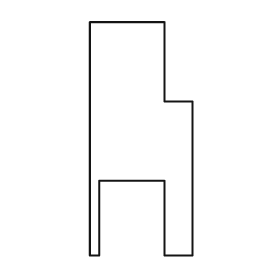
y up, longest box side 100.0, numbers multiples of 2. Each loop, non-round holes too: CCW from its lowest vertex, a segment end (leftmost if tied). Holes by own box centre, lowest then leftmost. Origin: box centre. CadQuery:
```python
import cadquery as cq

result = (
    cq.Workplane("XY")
    .moveTo(-22.0, -50.0)
    .lineTo(-18.0, -50.0)
    .lineTo(-18.0, -18.0)
    .lineTo(10.0, -18.0)
    .lineTo(10.0, -50.0)
    .lineTo(22.0, -50.0)
    .lineTo(22.0, 16.0)
    .lineTo(10.0, 16.0)
    .lineTo(10.0, 50.0)
    .lineTo(-22.0, 50.0)
    .close()
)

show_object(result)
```